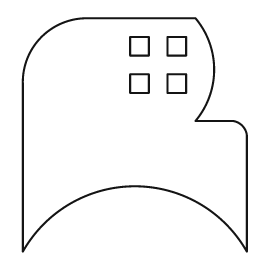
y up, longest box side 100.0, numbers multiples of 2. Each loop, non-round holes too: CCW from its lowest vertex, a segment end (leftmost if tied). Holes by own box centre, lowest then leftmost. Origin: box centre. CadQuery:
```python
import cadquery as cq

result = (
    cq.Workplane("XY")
    .moveTo(-48.0, -50.0)
    .threePointArc((0.0, -22.0), (48.0, -50.0))
    .lineTo(48.0, 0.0)
    .threePointArc((46.0, 4.0), (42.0, 6.0))
    .lineTo(26.0, 6.0)
    .threePointArc((34.0, 28.0), (26.0, 50.0))
    .lineTo(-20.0, 50.0)
    .threePointArc((-40.0, 42.0), (-48.0, 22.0))
    .close()
    .moveTo(-2.0, 18.0)
    .lineTo(6.0, 18.0)
    .lineTo(6.0, 26.0)
    .lineTo(-2.0, 26.0)
    .close()
    .moveTo(14.0, 18.0)
    .lineTo(22.0, 18.0)
    .lineTo(22.0, 26.0)
    .lineTo(14.0, 26.0)
    .close()
    .moveTo(-2.0, 34.0)
    .lineTo(6.0, 34.0)
    .lineTo(6.0, 42.0)
    .lineTo(-2.0, 42.0)
    .close()
    .moveTo(14.0, 34.0)
    .lineTo(22.0, 34.0)
    .lineTo(22.0, 42.0)
    .lineTo(14.0, 42.0)
    .close()
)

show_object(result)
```